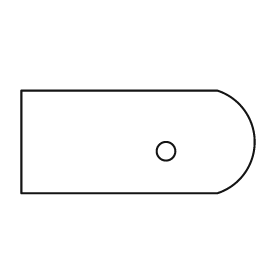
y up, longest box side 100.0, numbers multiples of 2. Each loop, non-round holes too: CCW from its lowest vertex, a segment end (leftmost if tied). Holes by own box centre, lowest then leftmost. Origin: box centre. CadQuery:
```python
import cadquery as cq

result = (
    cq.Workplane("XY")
    .moveTo(-50.0, -22.0)
    .lineTo(34.0, -22.0)
    .threePointArc((50.0, 0.0), (34.0, 22.0))
    .lineTo(-50.0, 22.0)
    .close()
    .moveTo(12.0, -4.0)
    .circle(4.0)
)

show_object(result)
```